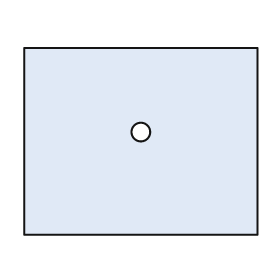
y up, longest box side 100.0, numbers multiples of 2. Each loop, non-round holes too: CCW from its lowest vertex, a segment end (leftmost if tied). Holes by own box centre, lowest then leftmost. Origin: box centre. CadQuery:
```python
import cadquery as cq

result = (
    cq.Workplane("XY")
    .moveTo(-50.0, -40.0)
    .lineTo(50.0, -40.0)
    .lineTo(50.0, 40.0)
    .lineTo(-50.0, 40.0)
    .close()
    .moveTo(0.0, 4.0)
    .circle(4.0)
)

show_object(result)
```